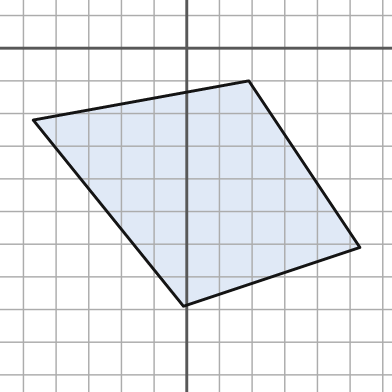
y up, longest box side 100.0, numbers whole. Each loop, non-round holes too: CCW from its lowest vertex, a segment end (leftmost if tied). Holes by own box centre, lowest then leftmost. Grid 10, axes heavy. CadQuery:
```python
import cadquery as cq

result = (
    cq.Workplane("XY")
    .moveTo(-1.0, -79.0)
    .lineTo(53.0, -61.0)
    .lineTo(19.0, -10.0)
    .lineTo(-47.0, -22.0)
    .close()
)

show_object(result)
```